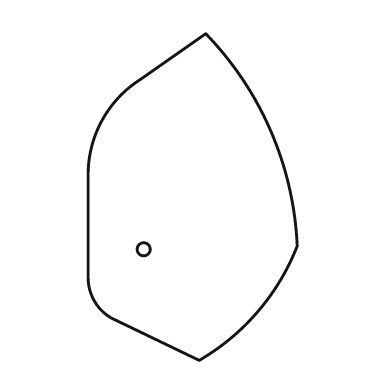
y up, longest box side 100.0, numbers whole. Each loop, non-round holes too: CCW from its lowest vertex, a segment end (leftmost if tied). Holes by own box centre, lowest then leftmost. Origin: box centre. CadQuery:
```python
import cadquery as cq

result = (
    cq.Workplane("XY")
    .moveTo(2.0, -50.0)
    .threePointArc((20.0, -35.0), (32.0, -15.0))
    .threePointArc((24.0, 20.0), (4.0, 50.0))
    .lineTo(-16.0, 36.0)
    .threePointArc((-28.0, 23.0), (-32.0, 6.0))
    .lineTo(-32.0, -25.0)
    .threePointArc((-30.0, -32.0), (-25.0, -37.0))
    .close()
    .moveTo(-15.0, -16.0)
    .circle(2.0)
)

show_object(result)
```